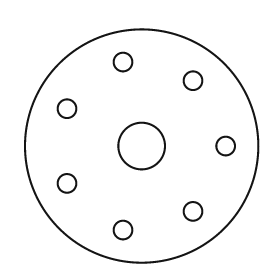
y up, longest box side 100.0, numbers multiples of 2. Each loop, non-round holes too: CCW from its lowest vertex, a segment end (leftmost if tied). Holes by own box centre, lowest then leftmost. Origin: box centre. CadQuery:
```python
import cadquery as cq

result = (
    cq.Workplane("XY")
    .moveTo(0.0, 0.0)
    .circle(50.0)
    .moveTo(-8.0, -36.0)
    .circle(4.0)
    .moveTo(22.0, -28.0)
    .circle(4.0)
    .moveTo(-32.0, -16.0)
    .circle(4.0)
    .moveTo(0.0, 0.0)
    .circle(10.0)
    .moveTo(36.0, 0.0)
    .circle(4.0)
    .moveTo(-32.0, 16.0)
    .circle(4.0)
    .moveTo(22.0, 28.0)
    .circle(4.0)
    .moveTo(-8.0, 36.0)
    .circle(4.0)
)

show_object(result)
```